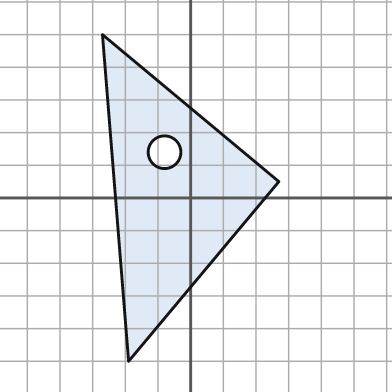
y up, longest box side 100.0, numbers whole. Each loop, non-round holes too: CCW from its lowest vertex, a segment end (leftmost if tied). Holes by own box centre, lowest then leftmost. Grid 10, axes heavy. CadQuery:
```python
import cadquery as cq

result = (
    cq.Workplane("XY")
    .moveTo(-19.0, -50.0)
    .lineTo(27.0, 5.0)
    .lineTo(-27.0, 50.0)
    .close()
    .moveTo(-8.0, 14.0)
    .circle(5.0)
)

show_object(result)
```